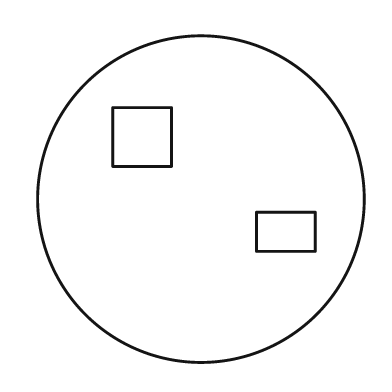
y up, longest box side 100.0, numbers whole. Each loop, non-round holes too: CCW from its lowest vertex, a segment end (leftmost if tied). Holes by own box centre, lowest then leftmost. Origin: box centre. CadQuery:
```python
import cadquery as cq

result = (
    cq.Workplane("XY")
    .moveTo(0.0, 0.0)
    .circle(50.0)
    .moveTo(17.0, -16.0)
    .lineTo(35.0, -16.0)
    .lineTo(35.0, -4.0)
    .lineTo(17.0, -4.0)
    .close()
    .moveTo(-27.0, 10.0)
    .lineTo(-9.0, 10.0)
    .lineTo(-9.0, 28.0)
    .lineTo(-27.0, 28.0)
    .close()
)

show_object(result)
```